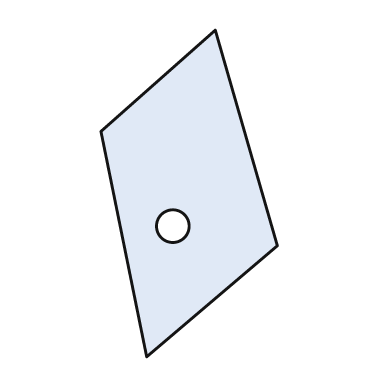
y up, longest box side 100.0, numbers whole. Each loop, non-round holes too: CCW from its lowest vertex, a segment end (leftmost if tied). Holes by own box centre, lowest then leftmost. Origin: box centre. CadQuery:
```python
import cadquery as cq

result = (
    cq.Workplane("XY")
    .moveTo(-13.0, -50.0)
    .lineTo(27.0, -16.0)
    .lineTo(8.0, 50.0)
    .lineTo(-27.0, 19.0)
    .close()
    .moveTo(-5.0, -10.0)
    .circle(5.0)
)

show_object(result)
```